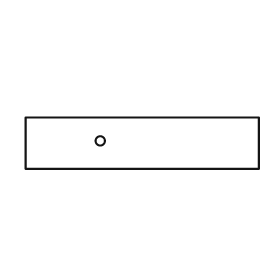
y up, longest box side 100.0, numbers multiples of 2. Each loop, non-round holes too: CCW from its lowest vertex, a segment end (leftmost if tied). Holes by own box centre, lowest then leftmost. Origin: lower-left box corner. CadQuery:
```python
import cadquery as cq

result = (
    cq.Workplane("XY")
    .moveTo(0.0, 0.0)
    .lineTo(100.0, 0.0)
    .lineTo(100.0, 22.0)
    .lineTo(0.0, 22.0)
    .close()
    .moveTo(32.0, 12.0)
    .circle(2.0)
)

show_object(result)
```